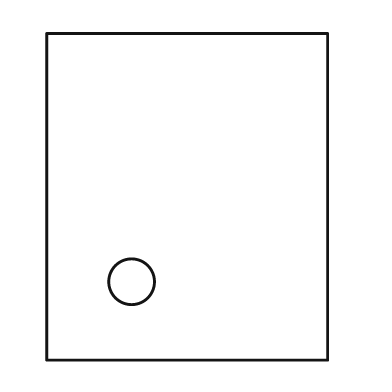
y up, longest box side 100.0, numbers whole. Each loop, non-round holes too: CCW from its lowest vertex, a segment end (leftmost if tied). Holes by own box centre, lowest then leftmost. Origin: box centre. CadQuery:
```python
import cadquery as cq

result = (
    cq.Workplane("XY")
    .moveTo(-43.0, -50.0)
    .lineTo(43.0, -50.0)
    .lineTo(43.0, 50.0)
    .lineTo(-43.0, 50.0)
    .close()
    .moveTo(-17.0, -26.0)
    .circle(7.0)
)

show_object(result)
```